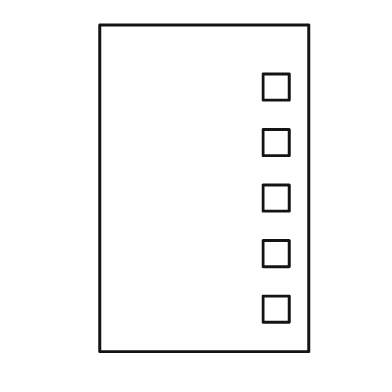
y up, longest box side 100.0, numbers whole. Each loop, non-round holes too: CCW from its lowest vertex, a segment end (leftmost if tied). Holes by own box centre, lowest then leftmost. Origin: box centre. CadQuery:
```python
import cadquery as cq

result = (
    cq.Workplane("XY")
    .moveTo(-32.0, -50.0)
    .lineTo(32.0, -50.0)
    .lineTo(32.0, 50.0)
    .lineTo(-32.0, 50.0)
    .close()
    .moveTo(18.0, -41.0)
    .lineTo(26.0, -41.0)
    .lineTo(26.0, -33.0)
    .lineTo(18.0, -33.0)
    .close()
    .moveTo(18.0, -24.0)
    .lineTo(26.0, -24.0)
    .lineTo(26.0, -16.0)
    .lineTo(18.0, -16.0)
    .close()
    .moveTo(18.0, -7.0)
    .lineTo(26.0, -7.0)
    .lineTo(26.0, 1.0)
    .lineTo(18.0, 1.0)
    .close()
    .moveTo(18.0, 10.0)
    .lineTo(26.0, 10.0)
    .lineTo(26.0, 18.0)
    .lineTo(18.0, 18.0)
    .close()
    .moveTo(18.0, 27.0)
    .lineTo(26.0, 27.0)
    .lineTo(26.0, 35.0)
    .lineTo(18.0, 35.0)
    .close()
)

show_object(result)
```